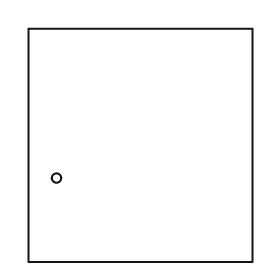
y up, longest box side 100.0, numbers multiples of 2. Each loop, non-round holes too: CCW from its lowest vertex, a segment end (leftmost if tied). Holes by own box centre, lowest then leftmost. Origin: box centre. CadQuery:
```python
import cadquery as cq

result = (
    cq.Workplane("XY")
    .moveTo(-48.0, -50.0)
    .lineTo(48.0, -50.0)
    .lineTo(48.0, 50.0)
    .lineTo(-48.0, 50.0)
    .close()
    .moveTo(-36.0, -14.0)
    .circle(2.0)
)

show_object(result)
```